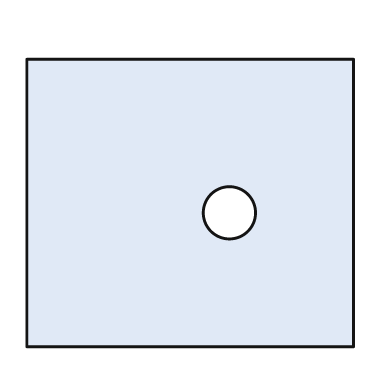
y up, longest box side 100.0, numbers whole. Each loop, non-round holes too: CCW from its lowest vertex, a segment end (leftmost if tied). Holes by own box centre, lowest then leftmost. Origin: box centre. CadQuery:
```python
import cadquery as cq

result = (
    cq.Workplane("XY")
    .moveTo(-50.0, -44.0)
    .lineTo(50.0, -44.0)
    .lineTo(50.0, 44.0)
    .lineTo(-50.0, 44.0)
    .close()
    .moveTo(12.0, -3.0)
    .circle(8.0)
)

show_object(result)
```